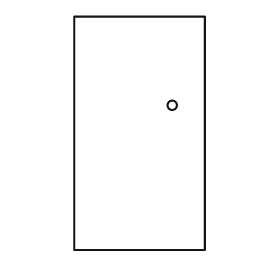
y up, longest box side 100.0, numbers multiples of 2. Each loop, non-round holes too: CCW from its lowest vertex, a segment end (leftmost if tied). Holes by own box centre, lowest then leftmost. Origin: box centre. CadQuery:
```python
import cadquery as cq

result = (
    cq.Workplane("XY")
    .moveTo(-28.0, -50.0)
    .lineTo(28.0, -50.0)
    .lineTo(28.0, 50.0)
    .lineTo(-28.0, 50.0)
    .close()
    .moveTo(14.0, 12.0)
    .circle(2.0)
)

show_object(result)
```